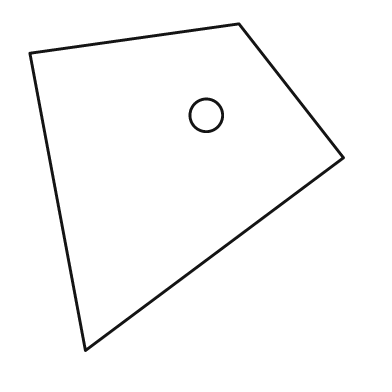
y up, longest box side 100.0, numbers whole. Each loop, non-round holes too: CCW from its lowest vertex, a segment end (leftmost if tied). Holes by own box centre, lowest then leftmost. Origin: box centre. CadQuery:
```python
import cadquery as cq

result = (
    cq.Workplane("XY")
    .moveTo(-31.0, -50.0)
    .lineTo(48.0, 9.0)
    .lineTo(16.0, 50.0)
    .lineTo(-48.0, 41.0)
    .close()
    .moveTo(6.0, 22.0)
    .circle(5.0)
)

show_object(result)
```